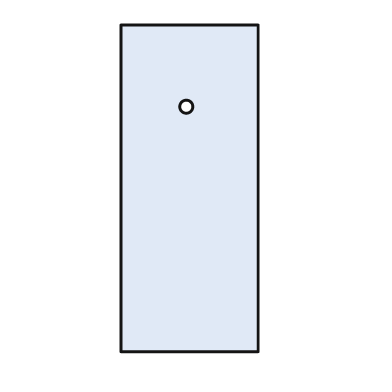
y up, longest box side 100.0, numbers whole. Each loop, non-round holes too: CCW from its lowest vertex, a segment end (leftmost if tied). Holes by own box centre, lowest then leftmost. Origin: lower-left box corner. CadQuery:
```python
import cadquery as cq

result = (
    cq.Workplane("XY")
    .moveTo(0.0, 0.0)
    .lineTo(42.0, 0.0)
    .lineTo(42.0, 100.0)
    .lineTo(0.0, 100.0)
    .close()
    .moveTo(20.0, 75.0)
    .circle(2.0)
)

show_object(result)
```